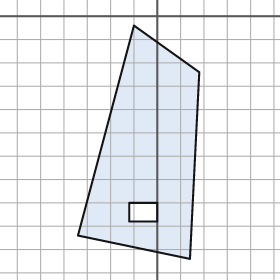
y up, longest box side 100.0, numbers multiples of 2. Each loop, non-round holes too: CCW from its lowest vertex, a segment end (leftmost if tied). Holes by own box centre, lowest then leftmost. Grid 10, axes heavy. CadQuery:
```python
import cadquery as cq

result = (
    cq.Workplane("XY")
    .moveTo(14.0, -104.0)
    .lineTo(18.0, -24.0)
    .lineTo(-10.0, -4.0)
    .lineTo(-34.0, -94.0)
    .close()
    .moveTo(-12.0, -88.0)
    .lineTo(0.0, -88.0)
    .lineTo(0.0, -80.0)
    .lineTo(-12.0, -80.0)
    .close()
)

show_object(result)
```